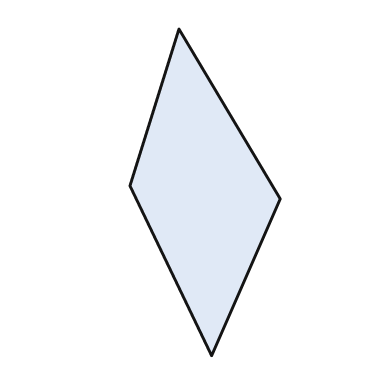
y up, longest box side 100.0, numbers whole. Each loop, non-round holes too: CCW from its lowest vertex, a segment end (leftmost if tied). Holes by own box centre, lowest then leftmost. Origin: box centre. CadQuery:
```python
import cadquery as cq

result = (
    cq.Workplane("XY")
    .moveTo(2.0, -50.0)
    .lineTo(23.0, -2.0)
    .lineTo(-8.0, 50.0)
    .lineTo(-23.0, 2.0)
    .close()
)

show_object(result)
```